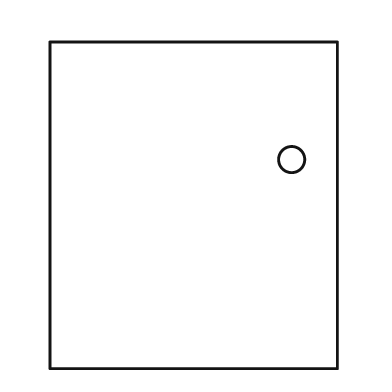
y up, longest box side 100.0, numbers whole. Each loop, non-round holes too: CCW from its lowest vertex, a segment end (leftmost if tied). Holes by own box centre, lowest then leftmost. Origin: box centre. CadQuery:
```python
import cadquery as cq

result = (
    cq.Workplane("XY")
    .moveTo(-44.0, -50.0)
    .lineTo(44.0, -50.0)
    .lineTo(44.0, 50.0)
    .lineTo(-44.0, 50.0)
    .close()
    .moveTo(30.0, 14.0)
    .circle(4.0)
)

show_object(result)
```